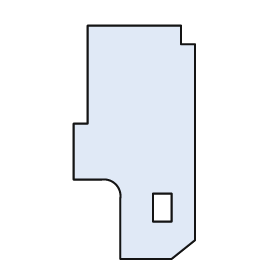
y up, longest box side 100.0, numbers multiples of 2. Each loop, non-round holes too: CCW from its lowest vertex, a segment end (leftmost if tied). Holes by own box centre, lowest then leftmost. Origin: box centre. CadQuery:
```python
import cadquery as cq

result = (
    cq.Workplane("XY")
    .moveTo(-6.0, -50.0)
    .lineTo(16.0, -50.0)
    .lineTo(26.0, -42.0)
    .lineTo(26.0, 42.0)
    .lineTo(20.0, 42.0)
    .lineTo(20.0, 50.0)
    .lineTo(-20.0, 50.0)
    .lineTo(-20.0, 8.0)
    .lineTo(-26.0, 8.0)
    .lineTo(-26.0, -16.0)
    .lineTo(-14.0, -16.0)
    .threePointArc((-8.0, -18.0), (-6.0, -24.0))
    .close()
    .moveTo(8.0, -34.0)
    .lineTo(16.0, -34.0)
    .lineTo(16.0, -22.0)
    .lineTo(8.0, -22.0)
    .close()
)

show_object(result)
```